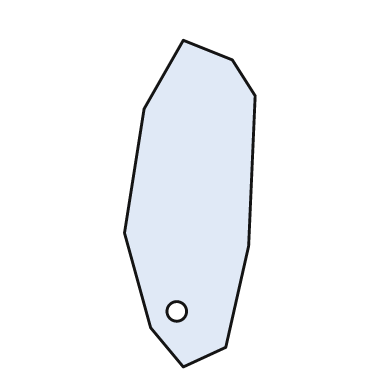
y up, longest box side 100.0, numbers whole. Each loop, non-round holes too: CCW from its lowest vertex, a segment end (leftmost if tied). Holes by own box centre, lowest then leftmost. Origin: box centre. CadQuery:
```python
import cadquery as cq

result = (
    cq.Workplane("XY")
    .moveTo(-2.0, -50.0)
    .lineTo(11.0, -44.0)
    .lineTo(18.0, -13.0)
    .lineTo(20.0, 33.0)
    .lineTo(13.0, 44.0)
    .lineTo(-2.0, 50.0)
    .lineTo(-14.0, 29.0)
    .lineTo(-20.0, -9.0)
    .lineTo(-12.0, -38.0)
    .close()
    .moveTo(-4.0, -33.0)
    .circle(3.0)
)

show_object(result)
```